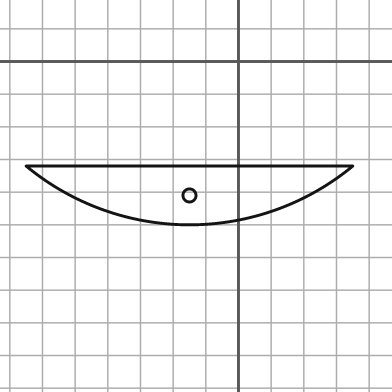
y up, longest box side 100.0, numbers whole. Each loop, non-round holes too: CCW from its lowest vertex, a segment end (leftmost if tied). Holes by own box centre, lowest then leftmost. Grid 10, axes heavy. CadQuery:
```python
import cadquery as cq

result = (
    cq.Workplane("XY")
    .moveTo(-65.0, -32.0)
    .threePointArc((-15.0, -50.0), (35.0, -32.0))
    .close()
    .moveTo(-15.0, -41.0)
    .circle(2.0)
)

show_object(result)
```